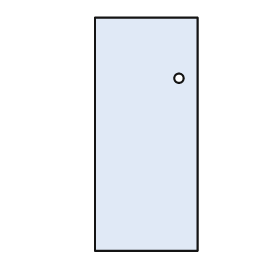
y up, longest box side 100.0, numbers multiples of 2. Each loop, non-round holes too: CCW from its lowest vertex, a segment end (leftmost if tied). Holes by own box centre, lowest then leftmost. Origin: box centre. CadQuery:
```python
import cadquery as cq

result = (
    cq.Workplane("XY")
    .moveTo(-22.0, -50.0)
    .lineTo(22.0, -50.0)
    .lineTo(22.0, 50.0)
    .lineTo(-22.0, 50.0)
    .close()
    .moveTo(14.0, 24.0)
    .circle(2.0)
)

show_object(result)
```